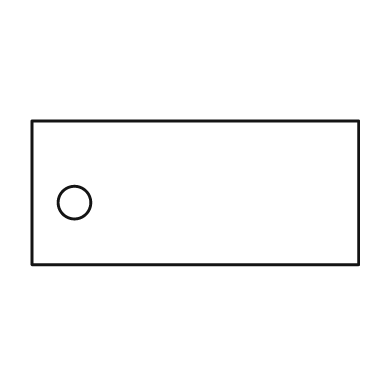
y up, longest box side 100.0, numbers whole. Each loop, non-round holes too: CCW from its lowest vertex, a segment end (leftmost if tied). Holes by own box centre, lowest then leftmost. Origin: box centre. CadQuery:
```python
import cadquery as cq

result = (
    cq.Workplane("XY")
    .moveTo(-50.0, -22.0)
    .lineTo(50.0, -22.0)
    .lineTo(50.0, 22.0)
    .lineTo(-50.0, 22.0)
    .close()
    .moveTo(-37.0, -3.0)
    .circle(5.0)
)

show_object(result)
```